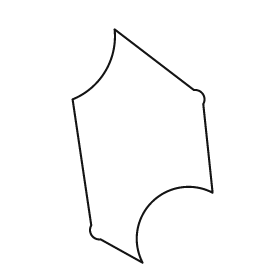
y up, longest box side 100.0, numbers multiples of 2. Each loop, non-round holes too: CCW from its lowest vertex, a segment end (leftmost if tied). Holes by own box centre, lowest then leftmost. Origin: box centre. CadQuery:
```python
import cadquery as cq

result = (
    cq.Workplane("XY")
    .moveTo(0.0, -50.0)
    .threePointArc((4.0, -24.0), (30.0, -20.0))
    .lineTo(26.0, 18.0)
    .threePointArc((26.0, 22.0), (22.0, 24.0))
    .lineTo(-12.0, 50.0)
    .threePointArc((-16.0, 32.0), (-30.0, 20.0))
    .lineTo(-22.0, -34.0)
    .threePointArc((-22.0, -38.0), (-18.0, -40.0))
    .close()
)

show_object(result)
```